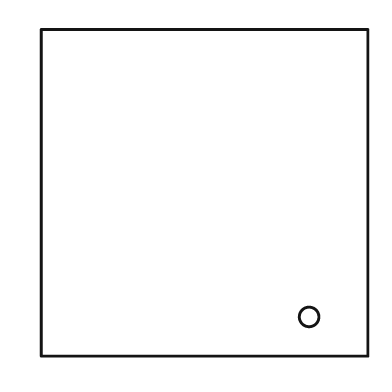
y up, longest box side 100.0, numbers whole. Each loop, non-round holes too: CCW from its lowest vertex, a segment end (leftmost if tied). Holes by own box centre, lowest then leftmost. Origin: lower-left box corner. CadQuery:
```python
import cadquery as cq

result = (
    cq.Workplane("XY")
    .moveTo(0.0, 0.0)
    .lineTo(100.0, 0.0)
    .lineTo(100.0, 100.0)
    .lineTo(0.0, 100.0)
    .close()
    .moveTo(82.0, 12.0)
    .circle(3.0)
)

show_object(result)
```